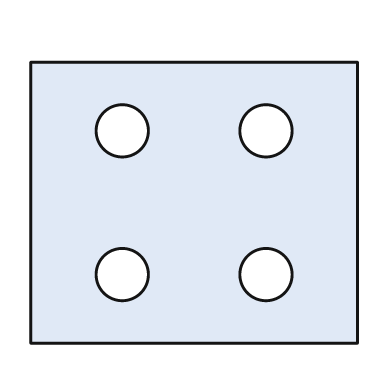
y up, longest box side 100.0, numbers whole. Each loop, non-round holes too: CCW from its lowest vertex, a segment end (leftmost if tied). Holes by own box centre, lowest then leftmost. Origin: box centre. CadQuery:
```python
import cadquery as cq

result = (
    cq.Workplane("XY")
    .moveTo(-50.0, -43.0)
    .lineTo(50.0, -43.0)
    .lineTo(50.0, 43.0)
    .lineTo(-50.0, 43.0)
    .close()
    .moveTo(-22.0, -22.0)
    .circle(8.0)
    .moveTo(22.0, -22.0)
    .circle(8.0)
    .moveTo(-22.0, 22.0)
    .circle(8.0)
    .moveTo(22.0, 22.0)
    .circle(8.0)
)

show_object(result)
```